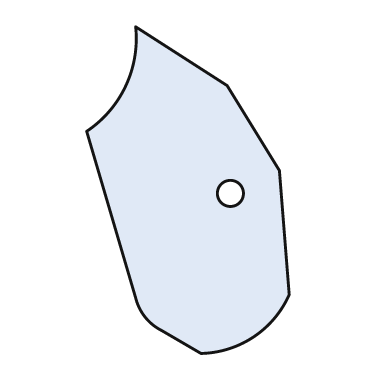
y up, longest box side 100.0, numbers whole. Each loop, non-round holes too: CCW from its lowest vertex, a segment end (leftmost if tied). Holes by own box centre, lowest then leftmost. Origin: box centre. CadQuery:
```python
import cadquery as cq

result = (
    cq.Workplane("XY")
    .moveTo(4.0, -50.0)
    .threePointArc((20.0, -45.0), (31.0, -32.0))
    .lineTo(28.0, 6.0)
    .lineTo(12.0, 32.0)
    .lineTo(-16.0, 50.0)
    .threePointArc((-19.0, 32.0), (-31.0, 18.0))
    .lineTo(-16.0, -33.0)
    .threePointArc((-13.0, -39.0), (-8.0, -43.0))
    .close()
    .moveTo(13.0, -1.0)
    .circle(4.0)
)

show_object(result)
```